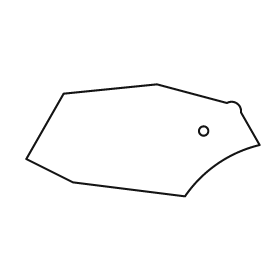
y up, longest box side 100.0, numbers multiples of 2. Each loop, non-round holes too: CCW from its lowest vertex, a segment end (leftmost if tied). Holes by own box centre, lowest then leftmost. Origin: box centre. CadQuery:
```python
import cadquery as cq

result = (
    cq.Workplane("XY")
    .moveTo(18.0, -24.0)
    .threePointArc((32.0, -10.0), (50.0, -2.0))
    .lineTo(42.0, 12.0)
    .threePointArc((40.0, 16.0), (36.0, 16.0))
    .lineTo(6.0, 24.0)
    .lineTo(-34.0, 20.0)
    .lineTo(-50.0, -8.0)
    .lineTo(-30.0, -18.0)
    .close()
    .moveTo(26.0, 4.0)
    .circle(2.0)
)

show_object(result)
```